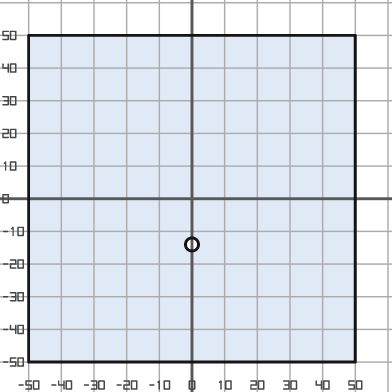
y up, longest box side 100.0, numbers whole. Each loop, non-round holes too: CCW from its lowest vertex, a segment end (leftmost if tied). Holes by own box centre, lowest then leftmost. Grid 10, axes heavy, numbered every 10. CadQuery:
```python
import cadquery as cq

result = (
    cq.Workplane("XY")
    .moveTo(-50.0, -50.0)
    .lineTo(50.0, -50.0)
    .lineTo(50.0, 50.0)
    .lineTo(-50.0, 50.0)
    .close()
    .moveTo(0.0, -14.0)
    .circle(2.0)
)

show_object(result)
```